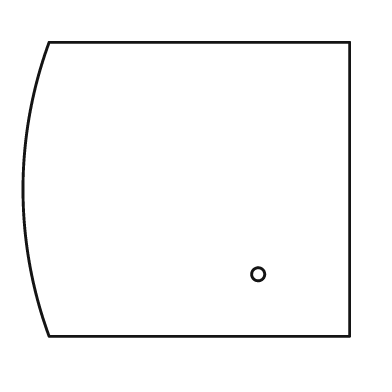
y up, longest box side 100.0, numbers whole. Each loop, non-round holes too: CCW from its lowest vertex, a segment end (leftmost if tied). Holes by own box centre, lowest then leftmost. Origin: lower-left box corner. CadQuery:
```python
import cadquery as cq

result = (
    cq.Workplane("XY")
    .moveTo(8.0, 0.0)
    .lineTo(100.0, 0.0)
    .lineTo(100.0, 90.0)
    .lineTo(8.0, 90.0)
    .threePointArc((0.0, 45.0), (8.0, 0.0))
    .close()
    .moveTo(72.0, 19.0)
    .circle(2.0)
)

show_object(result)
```